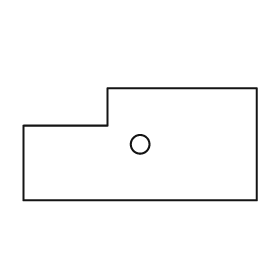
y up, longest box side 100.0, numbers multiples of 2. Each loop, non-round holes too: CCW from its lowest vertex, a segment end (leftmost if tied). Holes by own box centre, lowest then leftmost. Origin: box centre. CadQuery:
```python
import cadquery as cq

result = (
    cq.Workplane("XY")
    .moveTo(-50.0, -24.0)
    .lineTo(50.0, -24.0)
    .lineTo(50.0, 24.0)
    .lineTo(-14.0, 24.0)
    .lineTo(-14.0, 8.0)
    .lineTo(-50.0, 8.0)
    .close()
    .moveTo(0.0, 0.0)
    .circle(4.0)
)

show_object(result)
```